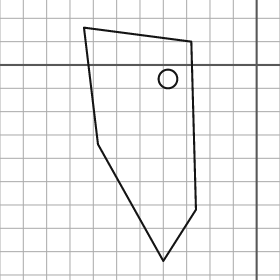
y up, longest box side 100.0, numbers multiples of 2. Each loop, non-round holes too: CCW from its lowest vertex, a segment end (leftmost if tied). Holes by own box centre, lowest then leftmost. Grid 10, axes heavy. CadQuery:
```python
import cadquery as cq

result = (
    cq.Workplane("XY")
    .moveTo(-40.0, -84.0)
    .lineTo(-26.0, -62.0)
    .lineTo(-28.0, 10.0)
    .lineTo(-74.0, 16.0)
    .lineTo(-68.0, -34.0)
    .close()
    .moveTo(-38.0, -6.0)
    .circle(4.0)
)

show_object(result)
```